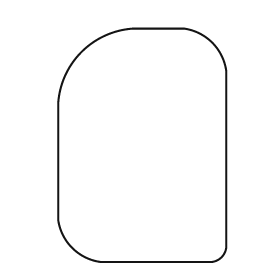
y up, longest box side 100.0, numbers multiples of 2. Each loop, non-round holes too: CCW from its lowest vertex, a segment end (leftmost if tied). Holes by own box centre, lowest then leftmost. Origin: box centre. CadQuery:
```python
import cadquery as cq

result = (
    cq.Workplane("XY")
    .moveTo(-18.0, -50.0)
    .lineTo(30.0, -50.0)
    .threePointArc((34.0, -48.0), (36.0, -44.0))
    .lineTo(36.0, 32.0)
    .threePointArc((30.0, 44.0), (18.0, 50.0))
    .lineTo(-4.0, 50.0)
    .threePointArc((-26.0, 40.0), (-36.0, 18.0))
    .lineTo(-36.0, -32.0)
    .threePointArc((-30.0, -44.0), (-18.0, -50.0))
    .close()
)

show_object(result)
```